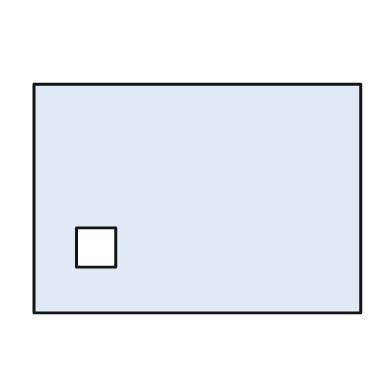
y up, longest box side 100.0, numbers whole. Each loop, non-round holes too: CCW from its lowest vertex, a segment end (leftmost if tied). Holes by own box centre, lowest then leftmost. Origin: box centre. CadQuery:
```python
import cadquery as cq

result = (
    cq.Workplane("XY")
    .moveTo(-50.0, -35.0)
    .lineTo(50.0, -35.0)
    .lineTo(50.0, 35.0)
    .lineTo(-50.0, 35.0)
    .close()
    .moveTo(-37.0, -21.0)
    .lineTo(-25.0, -21.0)
    .lineTo(-25.0, -9.0)
    .lineTo(-37.0, -9.0)
    .close()
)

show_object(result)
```